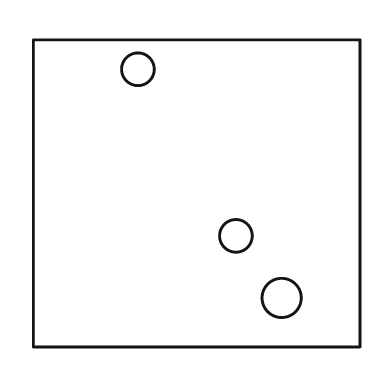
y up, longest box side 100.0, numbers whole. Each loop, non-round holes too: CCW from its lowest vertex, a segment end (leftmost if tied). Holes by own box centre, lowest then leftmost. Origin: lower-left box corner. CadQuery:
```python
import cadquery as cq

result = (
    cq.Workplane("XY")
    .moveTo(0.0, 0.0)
    .lineTo(100.0, 0.0)
    .lineTo(100.0, 94.0)
    .lineTo(0.0, 94.0)
    .close()
    .moveTo(76.0, 15.0)
    .circle(6.0)
    .moveTo(62.0, 34.0)
    .circle(5.0)
    .moveTo(32.0, 85.0)
    .circle(5.0)
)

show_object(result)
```